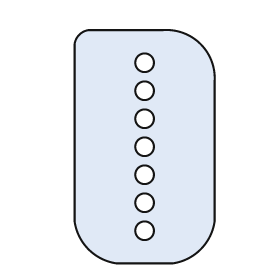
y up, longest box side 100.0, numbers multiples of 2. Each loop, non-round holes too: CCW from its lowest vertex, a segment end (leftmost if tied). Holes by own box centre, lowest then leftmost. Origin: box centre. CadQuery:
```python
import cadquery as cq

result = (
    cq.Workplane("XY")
    .moveTo(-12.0, -50.0)
    .lineTo(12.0, -50.0)
    .threePointArc((24.0, -44.0), (30.0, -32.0))
    .lineTo(30.0, 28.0)
    .threePointArc((24.0, 44.0), (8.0, 50.0))
    .lineTo(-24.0, 50.0)
    .threePointArc((-28.0, 48.0), (-30.0, 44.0))
    .lineTo(-30.0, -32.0)
    .threePointArc((-24.0, -44.0), (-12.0, -50.0))
    .close()
    .moveTo(0.0, -36.0)
    .circle(4.0)
    .moveTo(0.0, -24.0)
    .circle(4.0)
    .moveTo(0.0, -12.0)
    .circle(4.0)
    .moveTo(0.0, 0.0)
    .circle(4.0)
    .moveTo(0.0, 12.0)
    .circle(4.0)
    .moveTo(0.0, 24.0)
    .circle(4.0)
    .moveTo(0.0, 36.0)
    .circle(4.0)
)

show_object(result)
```